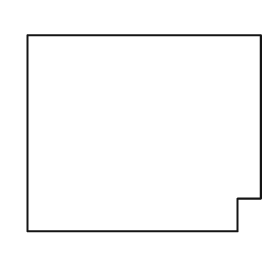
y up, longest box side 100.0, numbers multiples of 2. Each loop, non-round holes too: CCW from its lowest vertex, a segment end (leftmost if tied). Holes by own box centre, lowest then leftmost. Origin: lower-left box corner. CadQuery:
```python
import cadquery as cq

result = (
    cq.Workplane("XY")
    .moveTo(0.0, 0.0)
    .lineTo(90.0, 0.0)
    .lineTo(90.0, 14.0)
    .lineTo(100.0, 14.0)
    .lineTo(100.0, 84.0)
    .lineTo(0.0, 84.0)
    .close()
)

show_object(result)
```